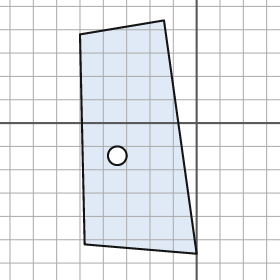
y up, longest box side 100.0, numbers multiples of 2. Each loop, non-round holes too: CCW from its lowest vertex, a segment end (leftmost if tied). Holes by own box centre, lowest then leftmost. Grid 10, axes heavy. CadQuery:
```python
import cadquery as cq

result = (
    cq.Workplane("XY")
    .moveTo(0.0, -56.0)
    .lineTo(-14.0, 44.0)
    .lineTo(-50.0, 38.0)
    .lineTo(-48.0, -52.0)
    .close()
    .moveTo(-34.0, -14.0)
    .circle(4.0)
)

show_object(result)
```